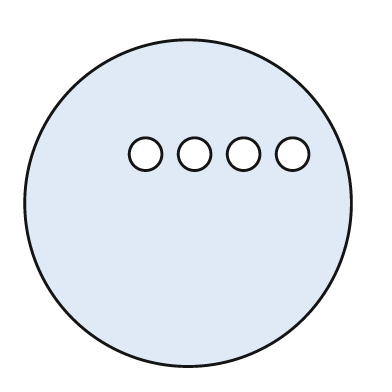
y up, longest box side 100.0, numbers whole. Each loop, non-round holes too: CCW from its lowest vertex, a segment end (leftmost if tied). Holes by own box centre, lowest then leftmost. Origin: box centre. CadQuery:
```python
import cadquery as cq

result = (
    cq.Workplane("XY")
    .moveTo(0.0, 0.0)
    .circle(50.0)
    .moveTo(-13.0, 15.0)
    .circle(5.0)
    .moveTo(2.0, 15.0)
    .circle(5.0)
    .moveTo(17.0, 15.0)
    .circle(5.0)
    .moveTo(32.0, 15.0)
    .circle(5.0)
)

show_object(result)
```